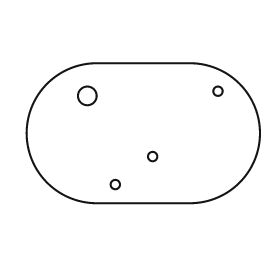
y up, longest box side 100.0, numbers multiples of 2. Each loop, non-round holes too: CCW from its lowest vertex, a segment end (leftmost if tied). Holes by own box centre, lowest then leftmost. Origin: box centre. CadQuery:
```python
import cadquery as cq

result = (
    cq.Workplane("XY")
    .moveTo(-20.0, -30.0)
    .lineTo(20.0, -30.0)
    .threePointArc((50.0, 0.0), (20.0, 30.0))
    .lineTo(-20.0, 30.0)
    .threePointArc((-50.0, 0.0), (-20.0, -30.0))
    .close()
    .moveTo(-12.0, -22.0)
    .circle(2.0)
    .moveTo(4.0, -10.0)
    .circle(2.0)
    .moveTo(-24.0, 16.0)
    .circle(4.0)
    .moveTo(32.0, 18.0)
    .circle(2.0)
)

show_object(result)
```